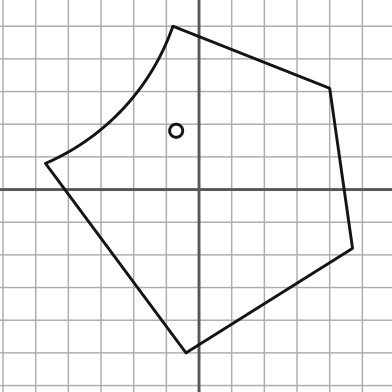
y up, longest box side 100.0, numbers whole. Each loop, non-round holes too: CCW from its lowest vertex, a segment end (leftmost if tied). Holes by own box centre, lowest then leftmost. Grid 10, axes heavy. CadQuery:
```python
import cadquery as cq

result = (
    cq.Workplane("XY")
    .moveTo(-4.0, -50.0)
    .lineTo(47.0, -18.0)
    .lineTo(40.0, 31.0)
    .lineTo(-8.0, 50.0)
    .threePointArc((-23.0, 25.0), (-47.0, 8.0))
    .close()
    .moveTo(-7.0, 18.0)
    .circle(2.0)
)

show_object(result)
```